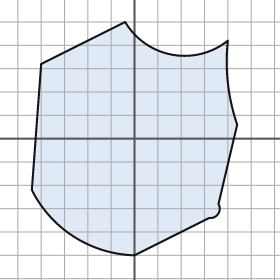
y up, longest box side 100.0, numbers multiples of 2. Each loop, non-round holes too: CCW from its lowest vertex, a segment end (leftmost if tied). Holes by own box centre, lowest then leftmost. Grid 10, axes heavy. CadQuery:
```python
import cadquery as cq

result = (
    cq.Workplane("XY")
    .moveTo(0.0, -50.0)
    .lineTo(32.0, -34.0)
    .threePointArc((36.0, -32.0), (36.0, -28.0))
    .lineTo(44.0, 6.0)
    .threePointArc((40.0, 24.0), (40.0, 42.0))
    .threePointArc((16.0, 36.0), (-4.0, 50.0))
    .lineTo(-40.0, 32.0)
    .lineTo(-44.0, -22.0)
    .threePointArc((-26.0, -42.0), (0.0, -50.0))
    .close()
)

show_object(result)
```